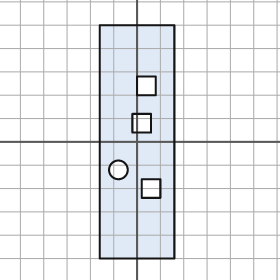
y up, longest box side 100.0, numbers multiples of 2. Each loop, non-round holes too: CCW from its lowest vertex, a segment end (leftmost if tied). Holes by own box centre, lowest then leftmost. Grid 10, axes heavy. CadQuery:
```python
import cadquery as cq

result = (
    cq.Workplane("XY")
    .moveTo(-16.0, -50.0)
    .lineTo(16.0, -50.0)
    .lineTo(16.0, 50.0)
    .lineTo(-16.0, 50.0)
    .close()
    .moveTo(2.0, -24.0)
    .lineTo(10.0, -24.0)
    .lineTo(10.0, -16.0)
    .lineTo(2.0, -16.0)
    .close()
    .moveTo(-8.0, -12.0)
    .circle(4.0)
    .moveTo(-2.0, 4.0)
    .lineTo(6.0, 4.0)
    .lineTo(6.0, 12.0)
    .lineTo(-2.0, 12.0)
    .close()
    .moveTo(0.0, 20.0)
    .lineTo(8.0, 20.0)
    .lineTo(8.0, 28.0)
    .lineTo(0.0, 28.0)
    .close()
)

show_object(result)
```